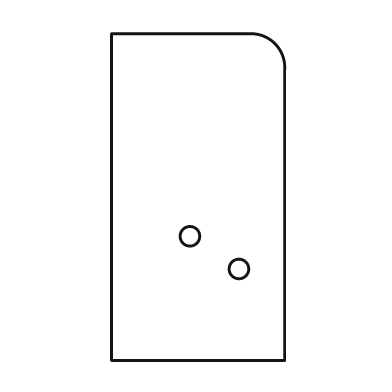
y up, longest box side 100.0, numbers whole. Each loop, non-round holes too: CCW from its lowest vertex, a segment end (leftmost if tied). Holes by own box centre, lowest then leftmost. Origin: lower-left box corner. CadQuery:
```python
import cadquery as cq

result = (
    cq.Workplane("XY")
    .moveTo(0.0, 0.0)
    .lineTo(53.0, 0.0)
    .lineTo(53.0, 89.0)
    .threePointArc((50.0, 97.0), (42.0, 100.0))
    .lineTo(0.0, 100.0)
    .close()
    .moveTo(39.0, 28.0)
    .circle(3.0)
    .moveTo(24.0, 38.0)
    .circle(3.0)
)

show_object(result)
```